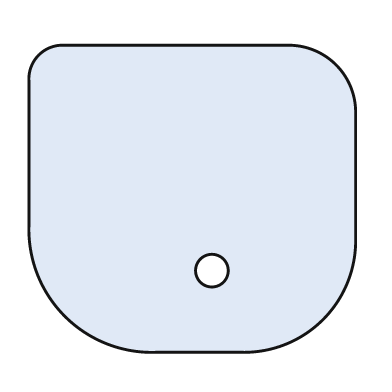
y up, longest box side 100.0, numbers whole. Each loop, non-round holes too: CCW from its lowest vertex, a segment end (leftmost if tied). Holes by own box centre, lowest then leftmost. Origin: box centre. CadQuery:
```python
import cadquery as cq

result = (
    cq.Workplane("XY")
    .moveTo(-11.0, -47.0)
    .lineTo(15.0, -47.0)
    .threePointArc((40.0, -37.0), (50.0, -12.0))
    .lineTo(50.0, 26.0)
    .threePointArc((44.0, 41.0), (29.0, 47.0))
    .lineTo(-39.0, 47.0)
    .threePointArc((-47.0, 44.0), (-50.0, 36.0))
    .lineTo(-50.0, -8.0)
    .threePointArc((-39.0, -36.0), (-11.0, -47.0))
    .close()
    .moveTo(6.0, -22.0)
    .circle(5.0)
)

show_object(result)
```